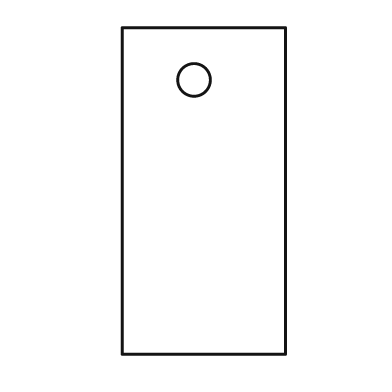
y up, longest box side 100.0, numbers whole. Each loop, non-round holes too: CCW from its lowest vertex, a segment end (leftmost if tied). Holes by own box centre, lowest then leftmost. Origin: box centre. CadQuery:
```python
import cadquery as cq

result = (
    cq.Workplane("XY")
    .moveTo(-25.0, -50.0)
    .lineTo(25.0, -50.0)
    .lineTo(25.0, 50.0)
    .lineTo(-25.0, 50.0)
    .close()
    .moveTo(-3.0, 34.0)
    .circle(5.0)
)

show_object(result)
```